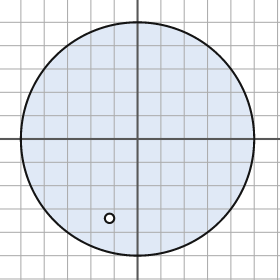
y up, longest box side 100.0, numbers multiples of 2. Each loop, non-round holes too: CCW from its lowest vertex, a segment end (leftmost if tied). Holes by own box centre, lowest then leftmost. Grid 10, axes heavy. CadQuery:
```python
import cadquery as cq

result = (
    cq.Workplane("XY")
    .moveTo(0.0, 0.0)
    .circle(50.0)
    .moveTo(-12.0, -34.0)
    .circle(2.0)
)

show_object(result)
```